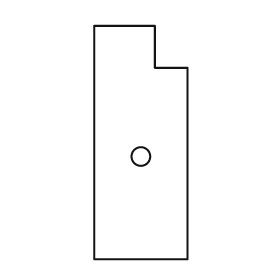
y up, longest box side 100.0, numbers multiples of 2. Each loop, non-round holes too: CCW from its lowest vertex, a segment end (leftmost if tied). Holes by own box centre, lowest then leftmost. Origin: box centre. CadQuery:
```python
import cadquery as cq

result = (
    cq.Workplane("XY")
    .moveTo(-20.0, -50.0)
    .lineTo(20.0, -50.0)
    .lineTo(20.0, 32.0)
    .lineTo(6.0, 32.0)
    .lineTo(6.0, 50.0)
    .lineTo(-20.0, 50.0)
    .close()
    .moveTo(0.0, -6.0)
    .circle(4.0)
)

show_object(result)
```